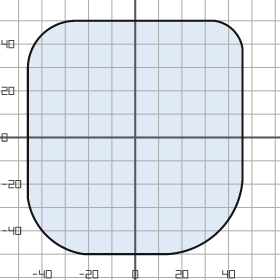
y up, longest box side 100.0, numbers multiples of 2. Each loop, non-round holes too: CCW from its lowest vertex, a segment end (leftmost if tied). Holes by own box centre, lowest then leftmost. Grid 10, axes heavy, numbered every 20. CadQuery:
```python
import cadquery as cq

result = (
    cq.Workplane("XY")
    .moveTo(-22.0, -50.0)
    .lineTo(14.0, -50.0)
    .threePointArc((36.0, -40.0), (46.0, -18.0))
    .lineTo(46.0, 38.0)
    .threePointArc((42.0, 46.0), (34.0, 50.0))
    .lineTo(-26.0, 50.0)
    .threePointArc((-40.0, 44.0), (-46.0, 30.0))
    .lineTo(-46.0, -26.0)
    .threePointArc((-38.0, -42.0), (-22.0, -50.0))
    .close()
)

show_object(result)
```